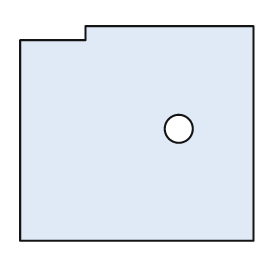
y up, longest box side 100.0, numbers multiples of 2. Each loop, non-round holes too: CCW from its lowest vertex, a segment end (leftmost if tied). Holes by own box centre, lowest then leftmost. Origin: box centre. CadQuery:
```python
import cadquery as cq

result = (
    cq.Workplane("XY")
    .moveTo(-50.0, -46.0)
    .lineTo(50.0, -46.0)
    .lineTo(50.0, 46.0)
    .lineTo(-22.0, 46.0)
    .lineTo(-22.0, 40.0)
    .lineTo(-50.0, 40.0)
    .close()
    .moveTo(18.0, 2.0)
    .circle(6.0)
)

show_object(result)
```